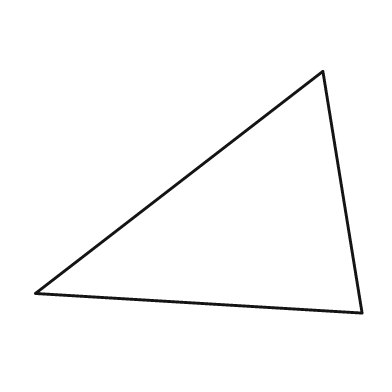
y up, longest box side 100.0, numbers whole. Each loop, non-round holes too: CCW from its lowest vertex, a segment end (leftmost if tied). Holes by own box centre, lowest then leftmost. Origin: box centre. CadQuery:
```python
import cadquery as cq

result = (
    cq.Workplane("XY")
    .moveTo(50.0, -37.0)
    .lineTo(38.0, 37.0)
    .lineTo(-50.0, -31.0)
    .close()
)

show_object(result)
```